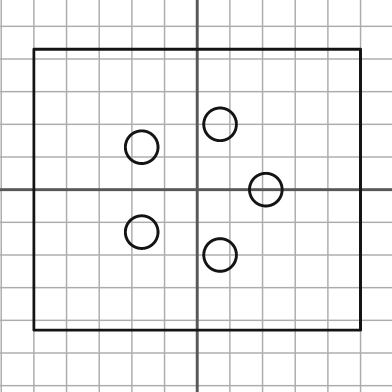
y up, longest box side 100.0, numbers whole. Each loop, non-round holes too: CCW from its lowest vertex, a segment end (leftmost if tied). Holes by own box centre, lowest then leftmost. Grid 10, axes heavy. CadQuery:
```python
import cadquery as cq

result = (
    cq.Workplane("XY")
    .moveTo(-50.0, -43.0)
    .lineTo(50.0, -43.0)
    .lineTo(50.0, 43.0)
    .lineTo(-50.0, 43.0)
    .close()
    .moveTo(7.0, -20.0)
    .circle(5.0)
    .moveTo(-17.0, -13.0)
    .circle(5.0)
    .moveTo(21.0, 0.0)
    .circle(5.0)
    .moveTo(-17.0, 13.0)
    .circle(5.0)
    .moveTo(7.0, 20.0)
    .circle(5.0)
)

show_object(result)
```